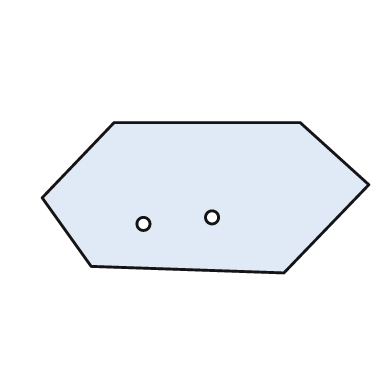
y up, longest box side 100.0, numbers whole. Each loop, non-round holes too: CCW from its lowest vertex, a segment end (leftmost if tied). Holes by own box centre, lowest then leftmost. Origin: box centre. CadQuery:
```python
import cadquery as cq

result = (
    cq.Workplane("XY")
    .moveTo(24.0, -23.0)
    .lineTo(50.0, 4.0)
    .lineTo(29.0, 23.0)
    .lineTo(-28.0, 23.0)
    .lineTo(-50.0, 0.0)
    .lineTo(-35.0, -21.0)
    .close()
    .moveTo(-19.0, -8.0)
    .circle(2.0)
    .moveTo(2.0, -6.0)
    .circle(2.0)
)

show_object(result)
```